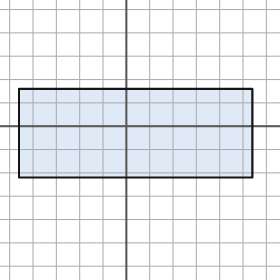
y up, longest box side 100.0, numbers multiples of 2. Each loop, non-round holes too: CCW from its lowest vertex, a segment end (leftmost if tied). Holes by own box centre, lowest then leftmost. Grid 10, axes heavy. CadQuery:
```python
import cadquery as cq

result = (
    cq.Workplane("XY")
    .moveTo(-46.0, -22.0)
    .lineTo(54.0, -22.0)
    .lineTo(54.0, 16.0)
    .lineTo(-46.0, 16.0)
    .close()
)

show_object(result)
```